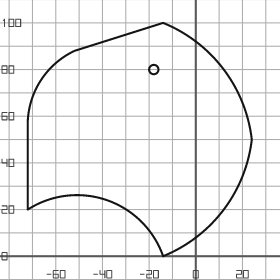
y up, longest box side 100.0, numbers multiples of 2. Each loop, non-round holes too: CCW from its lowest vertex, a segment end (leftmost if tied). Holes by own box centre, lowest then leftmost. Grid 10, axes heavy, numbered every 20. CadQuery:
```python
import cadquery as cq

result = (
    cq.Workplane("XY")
    .moveTo(-14.0, 0.0)
    .threePointArc((12.0, 20.0), (24.0, 50.0))
    .threePointArc((12.0, 80.0), (-14.0, 100.0))
    .lineTo(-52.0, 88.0)
    .threePointArc((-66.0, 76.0), (-72.0, 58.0))
    .lineTo(-72.0, 20.0)
    .threePointArc((-38.0, 24.0), (-14.0, 0.0))
    .close()
    .moveTo(-18.0, 80.0)
    .circle(2.0)
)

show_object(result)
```